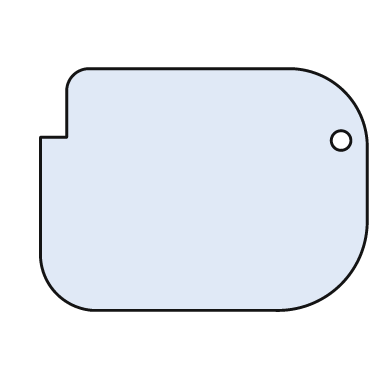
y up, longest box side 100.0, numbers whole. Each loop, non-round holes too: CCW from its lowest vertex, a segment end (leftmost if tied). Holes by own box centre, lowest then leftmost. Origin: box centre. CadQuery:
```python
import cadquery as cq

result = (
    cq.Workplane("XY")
    .moveTo(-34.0, -37.0)
    .lineTo(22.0, -37.0)
    .threePointArc((42.0, -29.0), (50.0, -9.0))
    .lineTo(50.0, 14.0)
    .threePointArc((43.0, 30.0), (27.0, 37.0))
    .lineTo(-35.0, 37.0)
    .threePointArc((-40.0, 35.0), (-42.0, 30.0))
    .lineTo(-42.0, 16.0)
    .lineTo(-50.0, 16.0)
    .lineTo(-50.0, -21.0)
    .threePointArc((-45.0, -32.0), (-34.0, -37.0))
    .close()
    .moveTo(42.0, 15.0)
    .circle(3.0)
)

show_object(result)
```